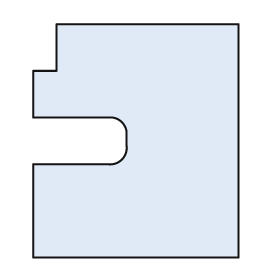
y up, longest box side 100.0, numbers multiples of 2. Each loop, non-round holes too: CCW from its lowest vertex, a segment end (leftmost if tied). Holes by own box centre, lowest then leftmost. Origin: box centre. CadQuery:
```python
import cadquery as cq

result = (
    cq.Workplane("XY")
    .moveTo(-44.0, -50.0)
    .lineTo(44.0, -50.0)
    .lineTo(44.0, 50.0)
    .lineTo(-34.0, 50.0)
    .lineTo(-34.0, 30.0)
    .lineTo(-44.0, 30.0)
    .lineTo(-44.0, 10.0)
    .lineTo(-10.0, 10.0)
    .threePointArc((-6.0, 8.0), (-4.0, 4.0))
    .lineTo(-4.0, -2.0)
    .threePointArc((-6.0, -8.0), (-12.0, -10.0))
    .lineTo(-44.0, -10.0)
    .close()
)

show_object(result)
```